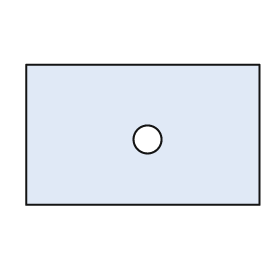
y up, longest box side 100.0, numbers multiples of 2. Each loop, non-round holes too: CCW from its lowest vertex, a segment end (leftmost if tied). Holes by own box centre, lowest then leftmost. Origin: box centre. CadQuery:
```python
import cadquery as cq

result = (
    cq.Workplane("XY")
    .moveTo(-50.0, -30.0)
    .lineTo(50.0, -30.0)
    .lineTo(50.0, 30.0)
    .lineTo(-50.0, 30.0)
    .close()
    .moveTo(2.0, -2.0)
    .circle(6.0)
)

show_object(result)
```